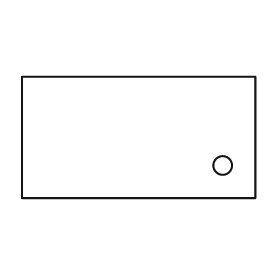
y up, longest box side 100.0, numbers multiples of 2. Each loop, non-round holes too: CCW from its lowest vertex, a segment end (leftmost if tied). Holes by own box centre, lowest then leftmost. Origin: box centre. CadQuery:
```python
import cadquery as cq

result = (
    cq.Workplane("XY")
    .moveTo(-50.0, -26.0)
    .lineTo(50.0, -26.0)
    .lineTo(50.0, 26.0)
    .lineTo(-50.0, 26.0)
    .close()
    .moveTo(36.0, -12.0)
    .circle(4.0)
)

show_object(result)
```